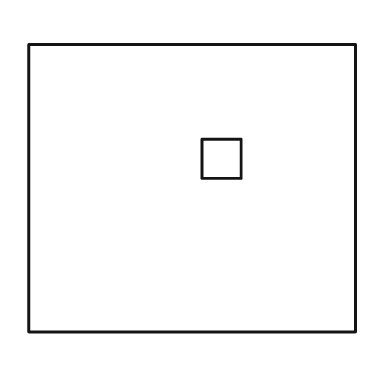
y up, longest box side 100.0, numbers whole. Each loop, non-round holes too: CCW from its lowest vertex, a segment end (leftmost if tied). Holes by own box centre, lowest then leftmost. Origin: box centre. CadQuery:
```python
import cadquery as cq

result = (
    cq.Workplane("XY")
    .moveTo(-50.0, -44.0)
    .lineTo(50.0, -44.0)
    .lineTo(50.0, 44.0)
    .lineTo(-50.0, 44.0)
    .close()
    .moveTo(3.0, 3.0)
    .lineTo(15.0, 3.0)
    .lineTo(15.0, 15.0)
    .lineTo(3.0, 15.0)
    .close()
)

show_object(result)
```